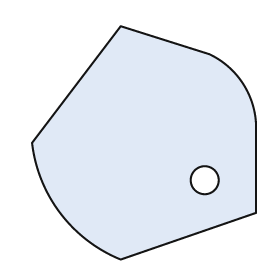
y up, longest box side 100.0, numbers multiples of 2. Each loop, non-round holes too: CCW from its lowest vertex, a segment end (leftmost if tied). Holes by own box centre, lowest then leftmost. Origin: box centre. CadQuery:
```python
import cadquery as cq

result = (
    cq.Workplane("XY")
    .moveTo(-10.0, -50.0)
    .lineTo(48.0, -30.0)
    .lineTo(48.0, 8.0)
    .threePointArc((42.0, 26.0), (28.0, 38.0))
    .lineTo(-10.0, 50.0)
    .lineTo(-48.0, 0.0)
    .threePointArc((-36.0, -30.0), (-10.0, -50.0))
    .close()
    .moveTo(26.0, -16.0)
    .circle(6.0)
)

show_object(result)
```